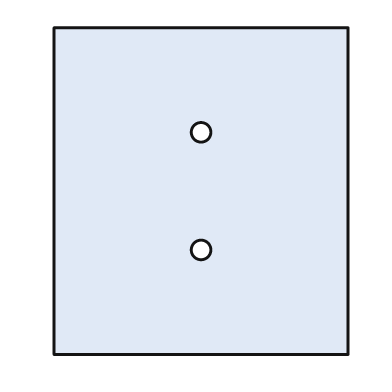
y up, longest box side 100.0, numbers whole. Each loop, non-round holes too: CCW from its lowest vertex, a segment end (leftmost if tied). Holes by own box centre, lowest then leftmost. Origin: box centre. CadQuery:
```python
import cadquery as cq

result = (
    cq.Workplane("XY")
    .moveTo(-45.0, -50.0)
    .lineTo(45.0, -50.0)
    .lineTo(45.0, 50.0)
    .lineTo(-45.0, 50.0)
    .close()
    .moveTo(0.0, -18.0)
    .circle(3.0)
    .moveTo(0.0, 18.0)
    .circle(3.0)
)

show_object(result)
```